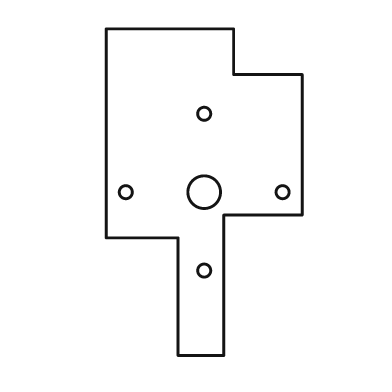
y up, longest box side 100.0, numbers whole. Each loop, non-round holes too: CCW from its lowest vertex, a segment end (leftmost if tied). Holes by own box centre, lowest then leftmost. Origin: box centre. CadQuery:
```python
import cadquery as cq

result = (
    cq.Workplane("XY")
    .moveTo(-8.0, -50.0)
    .lineTo(6.0, -50.0)
    .lineTo(6.0, -7.0)
    .lineTo(30.0, -7.0)
    .lineTo(30.0, 36.0)
    .lineTo(9.0, 36.0)
    .lineTo(9.0, 50.0)
    .lineTo(-30.0, 50.0)
    .lineTo(-30.0, -14.0)
    .lineTo(-8.0, -14.0)
    .close()
    .moveTo(0.0, -24.0)
    .circle(2.0)
    .moveTo(-24.0, 0.0)
    .circle(2.0)
    .moveTo(0.0, 0.0)
    .circle(5.0)
    .moveTo(24.0, 0.0)
    .circle(2.0)
    .moveTo(0.0, 24.0)
    .circle(2.0)
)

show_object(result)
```